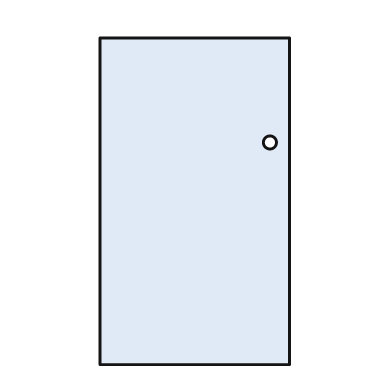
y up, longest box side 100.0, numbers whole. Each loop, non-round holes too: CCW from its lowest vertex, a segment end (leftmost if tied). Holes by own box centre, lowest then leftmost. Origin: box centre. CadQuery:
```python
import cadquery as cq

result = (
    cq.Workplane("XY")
    .moveTo(-29.0, -50.0)
    .lineTo(29.0, -50.0)
    .lineTo(29.0, 50.0)
    .lineTo(-29.0, 50.0)
    .close()
    .moveTo(23.0, 18.0)
    .circle(2.0)
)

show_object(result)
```